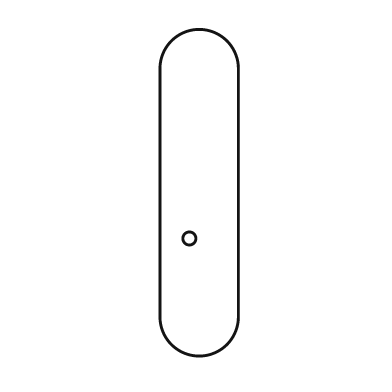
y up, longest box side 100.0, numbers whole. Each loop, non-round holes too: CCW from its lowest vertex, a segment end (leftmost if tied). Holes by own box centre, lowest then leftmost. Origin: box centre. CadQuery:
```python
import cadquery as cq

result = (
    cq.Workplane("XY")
    .moveTo(-12.0, -38.0)
    .threePointArc((0.0, -50.0), (12.0, -38.0))
    .lineTo(12.0, 38.0)
    .threePointArc((0.0, 50.0), (-12.0, 38.0))
    .close()
    .moveTo(-3.0, -14.0)
    .circle(2.0)
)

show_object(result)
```